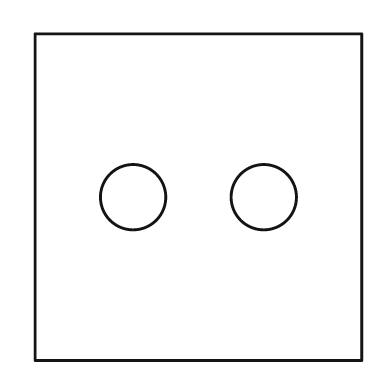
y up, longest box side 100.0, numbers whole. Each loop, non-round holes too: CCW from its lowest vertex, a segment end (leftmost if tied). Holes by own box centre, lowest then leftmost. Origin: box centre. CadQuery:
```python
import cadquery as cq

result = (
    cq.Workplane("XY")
    .moveTo(-50.0, -50.0)
    .lineTo(50.0, -50.0)
    .lineTo(50.0, 50.0)
    .lineTo(-50.0, 50.0)
    .close()
    .moveTo(-20.0, 0.0)
    .circle(10.0)
    .moveTo(20.0, 0.0)
    .circle(10.0)
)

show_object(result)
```